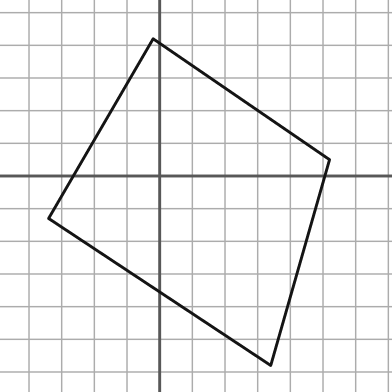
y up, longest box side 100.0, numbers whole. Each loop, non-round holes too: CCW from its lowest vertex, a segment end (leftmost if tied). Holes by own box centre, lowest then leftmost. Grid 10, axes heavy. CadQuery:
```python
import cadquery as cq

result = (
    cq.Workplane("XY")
    .moveTo(34.0, -58.0)
    .lineTo(52.0, 5.0)
    .lineTo(-2.0, 42.0)
    .lineTo(-34.0, -13.0)
    .close()
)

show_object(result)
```